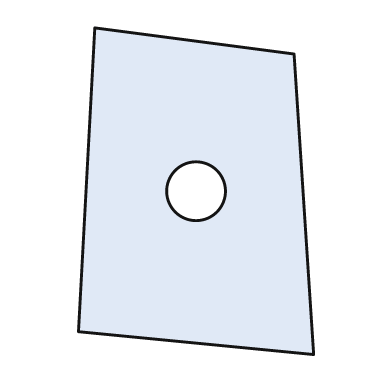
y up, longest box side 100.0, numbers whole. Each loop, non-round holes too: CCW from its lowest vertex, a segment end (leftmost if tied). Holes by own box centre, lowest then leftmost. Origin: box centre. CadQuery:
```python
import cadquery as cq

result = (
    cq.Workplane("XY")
    .moveTo(36.0, -50.0)
    .lineTo(30.0, 42.0)
    .lineTo(-31.0, 50.0)
    .lineTo(-36.0, -43.0)
    .close()
    .moveTo(0.0, 0.0)
    .circle(9.0)
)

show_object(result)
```